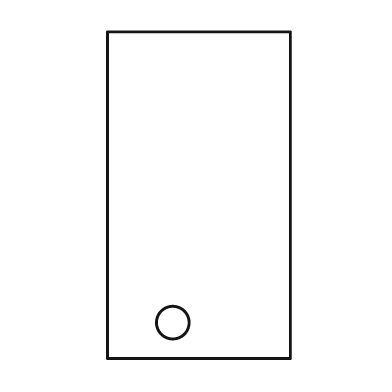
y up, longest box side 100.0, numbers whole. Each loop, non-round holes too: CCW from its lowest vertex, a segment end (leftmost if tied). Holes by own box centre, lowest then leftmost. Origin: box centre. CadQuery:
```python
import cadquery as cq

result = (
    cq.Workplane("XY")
    .moveTo(-28.0, -50.0)
    .lineTo(28.0, -50.0)
    .lineTo(28.0, 50.0)
    .lineTo(-28.0, 50.0)
    .close()
    .moveTo(-8.0, -39.0)
    .circle(5.0)
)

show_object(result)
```